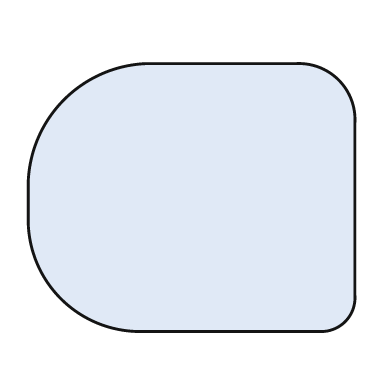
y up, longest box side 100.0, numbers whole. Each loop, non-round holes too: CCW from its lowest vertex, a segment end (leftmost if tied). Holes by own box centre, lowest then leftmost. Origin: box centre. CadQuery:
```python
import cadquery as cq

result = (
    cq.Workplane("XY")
    .moveTo(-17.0, -41.0)
    .lineTo(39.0, -41.0)
    .threePointArc((47.0, -38.0), (50.0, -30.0))
    .lineTo(50.0, 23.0)
    .threePointArc((45.0, 36.0), (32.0, 41.0))
    .lineTo(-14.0, 41.0)
    .threePointArc((-39.0, 30.0), (-50.0, 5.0))
    .lineTo(-50.0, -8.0)
    .threePointArc((-40.0, -31.0), (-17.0, -41.0))
    .close()
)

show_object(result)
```